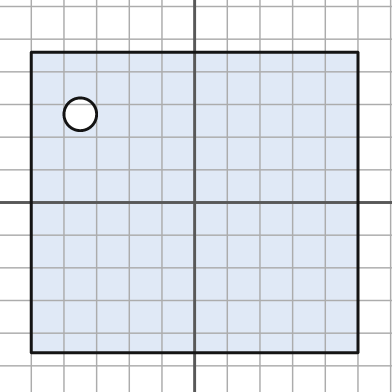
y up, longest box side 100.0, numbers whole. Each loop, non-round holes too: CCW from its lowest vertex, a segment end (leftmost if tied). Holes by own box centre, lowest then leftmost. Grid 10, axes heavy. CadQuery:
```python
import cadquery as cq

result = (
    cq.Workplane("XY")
    .moveTo(-50.0, -46.0)
    .lineTo(50.0, -46.0)
    .lineTo(50.0, 46.0)
    .lineTo(-50.0, 46.0)
    .close()
    .moveTo(-35.0, 27.0)
    .circle(5.0)
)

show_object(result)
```